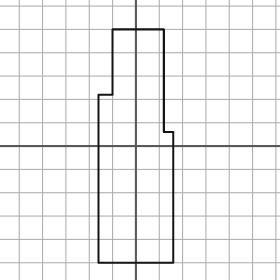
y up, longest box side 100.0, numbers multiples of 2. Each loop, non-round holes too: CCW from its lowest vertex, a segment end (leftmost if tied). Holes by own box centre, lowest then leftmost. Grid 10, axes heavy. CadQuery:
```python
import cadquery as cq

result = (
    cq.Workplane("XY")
    .moveTo(-16.0, -50.0)
    .lineTo(16.0, -50.0)
    .lineTo(16.0, 6.0)
    .lineTo(12.0, 6.0)
    .lineTo(12.0, 50.0)
    .lineTo(-10.0, 50.0)
    .lineTo(-10.0, 22.0)
    .lineTo(-16.0, 22.0)
    .close()
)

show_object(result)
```